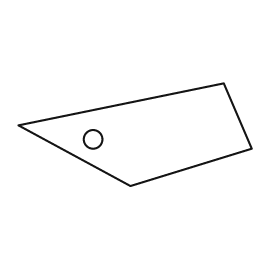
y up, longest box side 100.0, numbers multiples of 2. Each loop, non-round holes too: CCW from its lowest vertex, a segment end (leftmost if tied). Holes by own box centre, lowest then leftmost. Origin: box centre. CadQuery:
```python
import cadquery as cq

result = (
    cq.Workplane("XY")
    .moveTo(-2.0, -22.0)
    .lineTo(50.0, -6.0)
    .lineTo(38.0, 22.0)
    .lineTo(-50.0, 4.0)
    .close()
    .moveTo(-18.0, -2.0)
    .circle(4.0)
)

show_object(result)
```